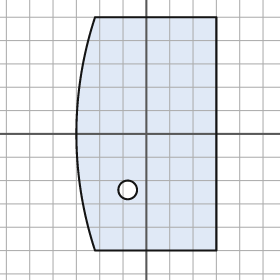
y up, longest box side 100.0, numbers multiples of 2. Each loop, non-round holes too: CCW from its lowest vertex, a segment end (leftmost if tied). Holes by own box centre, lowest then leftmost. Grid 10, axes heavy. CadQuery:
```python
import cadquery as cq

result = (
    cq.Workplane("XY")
    .moveTo(-22.0, -50.0)
    .lineTo(30.0, -50.0)
    .lineTo(30.0, 50.0)
    .lineTo(-22.0, 50.0)
    .threePointArc((-30.0, 0.0), (-22.0, -50.0))
    .close()
    .moveTo(-8.0, -24.0)
    .circle(4.0)
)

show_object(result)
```